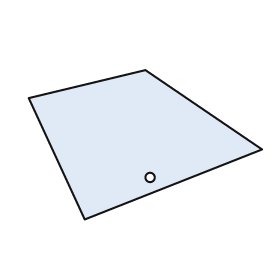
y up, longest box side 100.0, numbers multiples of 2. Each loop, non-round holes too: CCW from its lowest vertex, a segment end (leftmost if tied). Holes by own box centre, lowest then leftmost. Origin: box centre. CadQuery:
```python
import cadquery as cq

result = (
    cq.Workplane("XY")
    .moveTo(-26.0, -32.0)
    .lineTo(50.0, -2.0)
    .lineTo(0.0, 32.0)
    .lineTo(-50.0, 20.0)
    .close()
    .moveTo(2.0, -14.0)
    .circle(2.0)
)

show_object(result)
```